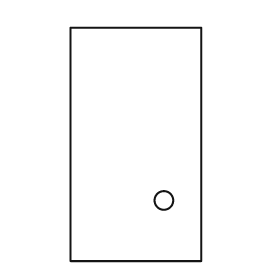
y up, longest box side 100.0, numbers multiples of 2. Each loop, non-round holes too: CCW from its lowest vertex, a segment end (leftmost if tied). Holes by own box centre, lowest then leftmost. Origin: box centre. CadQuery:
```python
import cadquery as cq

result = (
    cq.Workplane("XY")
    .moveTo(-28.0, -50.0)
    .lineTo(28.0, -50.0)
    .lineTo(28.0, 50.0)
    .lineTo(-28.0, 50.0)
    .close()
    .moveTo(12.0, -24.0)
    .circle(4.0)
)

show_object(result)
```